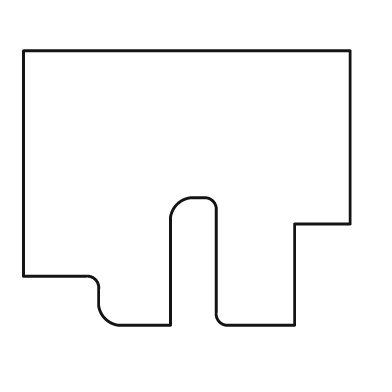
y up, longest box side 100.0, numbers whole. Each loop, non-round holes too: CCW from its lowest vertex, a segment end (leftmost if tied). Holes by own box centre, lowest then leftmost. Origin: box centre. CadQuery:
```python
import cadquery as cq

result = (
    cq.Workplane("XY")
    .moveTo(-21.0, -42.0)
    .lineTo(-5.0, -42.0)
    .lineTo(-5.0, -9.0)
    .threePointArc((-3.0, -5.0), (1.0, -3.0))
    .lineTo(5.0, -3.0)
    .threePointArc((8.0, -4.0), (9.0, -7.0))
    .lineTo(9.0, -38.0)
    .threePointArc((10.0, -41.0), (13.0, -42.0))
    .lineTo(33.0, -42.0)
    .lineTo(33.0, -11.0)
    .lineTo(50.0, -11.0)
    .lineTo(50.0, 42.0)
    .lineTo(-50.0, 42.0)
    .lineTo(-50.0, -27.0)
    .lineTo(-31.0, -27.0)
    .threePointArc((-28.0, -28.0), (-27.0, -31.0))
    .lineTo(-27.0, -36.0)
    .threePointArc((-25.0, -40.0), (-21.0, -42.0))
    .close()
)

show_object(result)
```